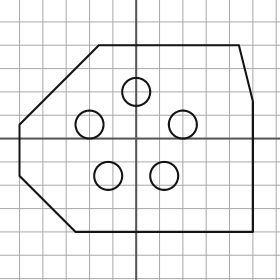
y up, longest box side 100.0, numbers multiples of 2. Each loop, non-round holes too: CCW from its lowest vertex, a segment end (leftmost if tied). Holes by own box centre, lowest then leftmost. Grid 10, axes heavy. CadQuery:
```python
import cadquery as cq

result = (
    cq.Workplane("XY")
    .moveTo(-26.0, -40.0)
    .lineTo(50.0, -40.0)
    .lineTo(50.0, 16.0)
    .lineTo(44.0, 40.0)
    .lineTo(-16.0, 40.0)
    .lineTo(-50.0, 6.0)
    .lineTo(-50.0, -16.0)
    .close()
    .moveTo(-12.0, -16.0)
    .circle(6.0)
    .moveTo(12.0, -16.0)
    .circle(6.0)
    .moveTo(-20.0, 6.0)
    .circle(6.0)
    .moveTo(20.0, 6.0)
    .circle(6.0)
    .moveTo(0.0, 20.0)
    .circle(6.0)
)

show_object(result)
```